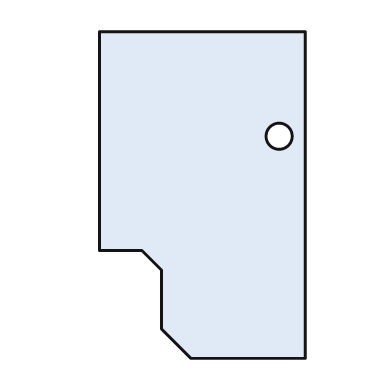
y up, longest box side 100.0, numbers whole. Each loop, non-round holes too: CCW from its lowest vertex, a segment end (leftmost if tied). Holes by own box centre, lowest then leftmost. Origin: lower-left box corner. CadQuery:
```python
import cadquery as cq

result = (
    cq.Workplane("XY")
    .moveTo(28.0, 0.0)
    .lineTo(63.0, 0.0)
    .lineTo(63.0, 100.0)
    .lineTo(0.0, 100.0)
    .lineTo(0.0, 33.0)
    .lineTo(13.0, 33.0)
    .lineTo(19.0, 27.0)
    .lineTo(19.0, 9.0)
    .close()
    .moveTo(55.0, 68.0)
    .circle(4.0)
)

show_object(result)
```